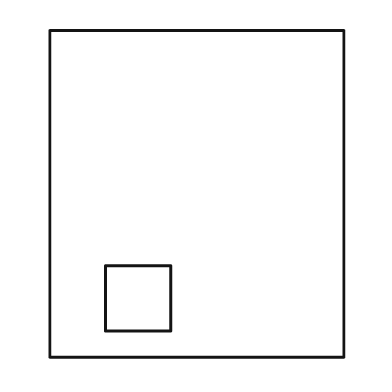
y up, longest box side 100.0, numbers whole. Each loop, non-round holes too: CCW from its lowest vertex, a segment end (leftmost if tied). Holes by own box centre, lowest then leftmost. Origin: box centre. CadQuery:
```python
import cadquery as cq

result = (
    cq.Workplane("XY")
    .moveTo(-45.0, -50.0)
    .lineTo(45.0, -50.0)
    .lineTo(45.0, 50.0)
    .lineTo(-45.0, 50.0)
    .close()
    .moveTo(-28.0, -42.0)
    .lineTo(-8.0, -42.0)
    .lineTo(-8.0, -22.0)
    .lineTo(-28.0, -22.0)
    .close()
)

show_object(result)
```